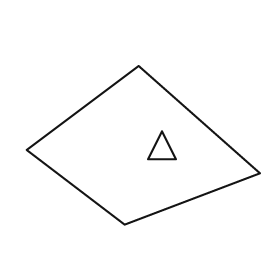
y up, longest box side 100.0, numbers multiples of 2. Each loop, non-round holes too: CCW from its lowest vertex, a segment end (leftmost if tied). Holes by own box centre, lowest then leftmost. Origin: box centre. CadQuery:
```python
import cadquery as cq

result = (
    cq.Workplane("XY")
    .moveTo(-8.0, -34.0)
    .lineTo(50.0, -12.0)
    .lineTo(-2.0, 34.0)
    .lineTo(-50.0, -2.0)
    .close()
    .moveTo(2.0, -6.0)
    .lineTo(14.0, -6.0)
    .lineTo(8.0, 6.0)
    .close()
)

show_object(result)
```